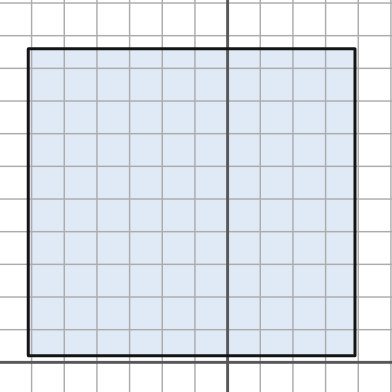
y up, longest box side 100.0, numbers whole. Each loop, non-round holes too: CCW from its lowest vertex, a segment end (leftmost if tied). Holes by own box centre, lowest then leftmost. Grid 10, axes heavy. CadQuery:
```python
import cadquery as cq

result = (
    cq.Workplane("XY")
    .moveTo(-61.0, 2.0)
    .lineTo(39.0, 2.0)
    .lineTo(39.0, 96.0)
    .lineTo(-61.0, 96.0)
    .close()
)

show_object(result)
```